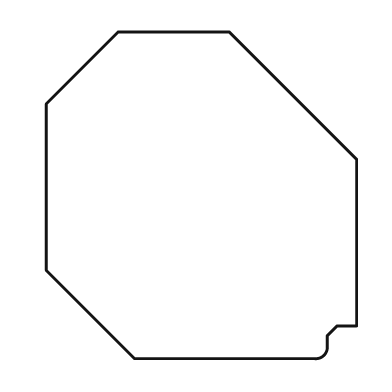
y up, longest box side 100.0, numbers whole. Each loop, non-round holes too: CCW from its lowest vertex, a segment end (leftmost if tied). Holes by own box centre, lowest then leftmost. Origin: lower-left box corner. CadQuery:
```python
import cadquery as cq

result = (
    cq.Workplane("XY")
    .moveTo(27.0, 0.0)
    .lineTo(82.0, 0.0)
    .threePointArc((85.0, 1.0), (86.0, 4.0))
    .lineTo(86.0, 7.0)
    .lineTo(89.0, 10.0)
    .lineTo(95.0, 10.0)
    .lineTo(95.0, 61.0)
    .lineTo(56.0, 100.0)
    .lineTo(22.0, 100.0)
    .lineTo(0.0, 78.0)
    .lineTo(0.0, 27.0)
    .close()
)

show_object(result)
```